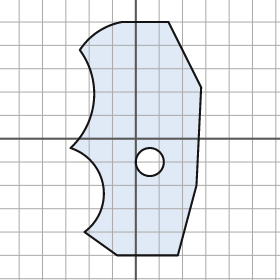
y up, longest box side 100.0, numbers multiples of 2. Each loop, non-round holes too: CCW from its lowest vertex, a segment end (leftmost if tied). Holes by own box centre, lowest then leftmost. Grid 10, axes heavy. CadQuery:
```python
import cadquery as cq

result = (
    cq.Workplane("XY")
    .moveTo(-8.0, -50.0)
    .lineTo(18.0, -50.0)
    .lineTo(26.0, -20.0)
    .lineTo(28.0, 22.0)
    .lineTo(14.0, 50.0)
    .lineTo(-6.0, 50.0)
    .threePointArc((-16.0, 46.0), (-24.0, 38.0))
    .threePointArc((-18.0, 16.0), (-28.0, -4.0))
    .threePointArc((-14.0, -20.0), (-22.0, -40.0))
    .close()
    .moveTo(6.0, -10.0)
    .circle(6.0)
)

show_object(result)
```